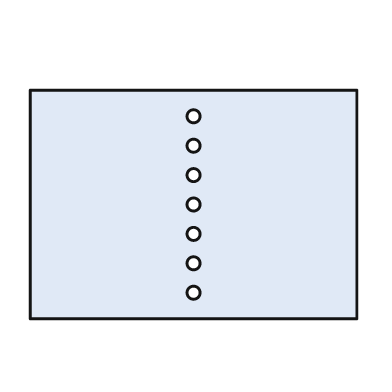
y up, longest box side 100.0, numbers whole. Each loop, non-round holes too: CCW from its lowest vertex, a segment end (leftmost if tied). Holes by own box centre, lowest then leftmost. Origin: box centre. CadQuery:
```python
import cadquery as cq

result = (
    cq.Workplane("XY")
    .moveTo(-50.0, -35.0)
    .lineTo(50.0, -35.0)
    .lineTo(50.0, 35.0)
    .lineTo(-50.0, 35.0)
    .close()
    .moveTo(0.0, -27.0)
    .circle(2.0)
    .moveTo(0.0, -18.0)
    .circle(2.0)
    .moveTo(0.0, -9.0)
    .circle(2.0)
    .moveTo(0.0, 0.0)
    .circle(2.0)
    .moveTo(0.0, 9.0)
    .circle(2.0)
    .moveTo(0.0, 18.0)
    .circle(2.0)
    .moveTo(0.0, 27.0)
    .circle(2.0)
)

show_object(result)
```